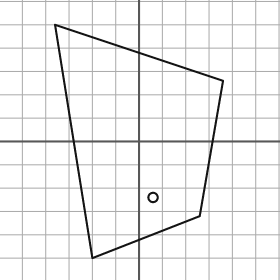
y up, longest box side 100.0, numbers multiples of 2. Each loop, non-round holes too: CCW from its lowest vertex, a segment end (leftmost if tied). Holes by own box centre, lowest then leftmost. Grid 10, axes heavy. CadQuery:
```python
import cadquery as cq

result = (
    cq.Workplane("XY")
    .moveTo(-20.0, -50.0)
    .lineTo(26.0, -32.0)
    .lineTo(36.0, 26.0)
    .lineTo(-36.0, 50.0)
    .close()
    .moveTo(6.0, -24.0)
    .circle(2.0)
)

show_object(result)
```